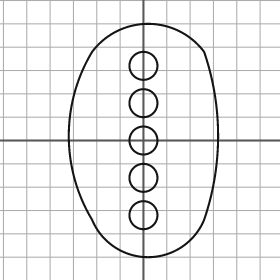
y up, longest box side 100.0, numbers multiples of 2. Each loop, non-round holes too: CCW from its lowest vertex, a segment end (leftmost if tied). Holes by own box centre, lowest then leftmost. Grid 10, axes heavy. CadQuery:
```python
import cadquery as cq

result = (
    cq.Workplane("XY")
    .moveTo(-22.0, -34.0)
    .threePointArc((2.0, -50.0), (26.0, -34.0))
    .threePointArc((32.0, 2.0), (26.0, 38.0))
    .threePointArc((2.0, 50.0), (-22.0, 38.0))
    .threePointArc((-32.0, 2.0), (-22.0, -34.0))
    .close()
    .moveTo(0.0, -32.0)
    .circle(6.0)
    .moveTo(0.0, -16.0)
    .circle(6.0)
    .moveTo(0.0, 0.0)
    .circle(6.0)
    .moveTo(0.0, 16.0)
    .circle(6.0)
    .moveTo(0.0, 32.0)
    .circle(6.0)
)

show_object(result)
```